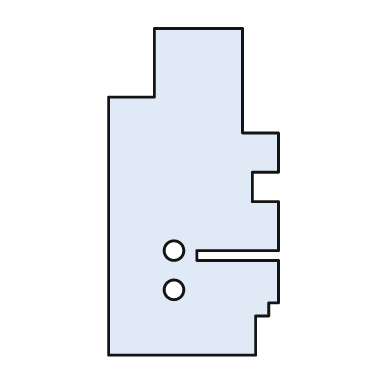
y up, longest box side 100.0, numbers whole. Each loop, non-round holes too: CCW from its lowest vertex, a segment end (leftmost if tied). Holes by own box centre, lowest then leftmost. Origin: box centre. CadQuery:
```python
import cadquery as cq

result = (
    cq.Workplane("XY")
    .moveTo(-26.0, -50.0)
    .lineTo(19.0, -50.0)
    .lineTo(19.0, -38.0)
    .lineTo(23.0, -38.0)
    .lineTo(23.0, -34.0)
    .lineTo(26.0, -34.0)
    .lineTo(26.0, -21.0)
    .lineTo(1.0, -21.0)
    .lineTo(1.0, -18.0)
    .lineTo(26.0, -18.0)
    .lineTo(26.0, -3.0)
    .lineTo(18.0, -3.0)
    .lineTo(18.0, 6.0)
    .lineTo(26.0, 6.0)
    .lineTo(26.0, 18.0)
    .lineTo(15.0, 18.0)
    .lineTo(15.0, 50.0)
    .lineTo(-12.0, 50.0)
    .lineTo(-12.0, 29.0)
    .lineTo(-26.0, 29.0)
    .close()
    .moveTo(-6.0, -30.0)
    .circle(3.0)
    .moveTo(-6.0, -18.0)
    .circle(3.0)
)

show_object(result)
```